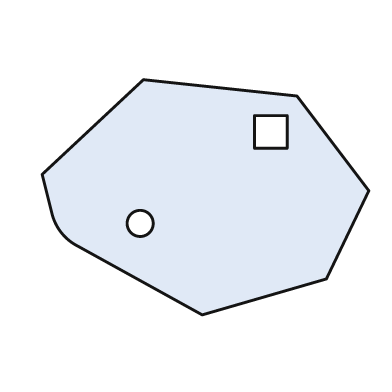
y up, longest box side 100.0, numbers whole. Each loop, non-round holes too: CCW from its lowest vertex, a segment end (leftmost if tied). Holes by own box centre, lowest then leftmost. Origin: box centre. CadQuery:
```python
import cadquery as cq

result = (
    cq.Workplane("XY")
    .moveTo(-1.0, -36.0)
    .lineTo(37.0, -25.0)
    .lineTo(50.0, 2.0)
    .lineTo(28.0, 31.0)
    .lineTo(-19.0, 36.0)
    .lineTo(-50.0, 7.0)
    .lineTo(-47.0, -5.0)
    .threePointArc((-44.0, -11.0), (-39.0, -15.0))
    .close()
    .moveTo(-20.0, -8.0)
    .circle(4.0)
    .moveTo(15.0, 15.0)
    .lineTo(25.0, 15.0)
    .lineTo(25.0, 25.0)
    .lineTo(15.0, 25.0)
    .close()
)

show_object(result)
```